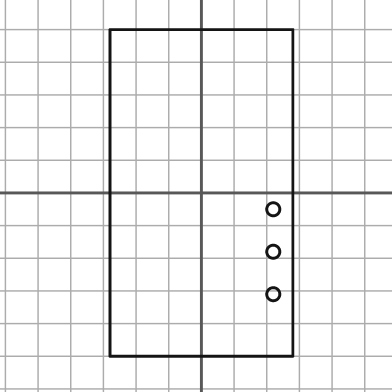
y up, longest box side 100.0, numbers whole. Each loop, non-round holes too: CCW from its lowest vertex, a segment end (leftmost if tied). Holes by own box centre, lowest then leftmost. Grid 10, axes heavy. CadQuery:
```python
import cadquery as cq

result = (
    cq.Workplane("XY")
    .moveTo(-28.0, -50.0)
    .lineTo(28.0, -50.0)
    .lineTo(28.0, 50.0)
    .lineTo(-28.0, 50.0)
    .close()
    .moveTo(22.0, -31.0)
    .circle(2.0)
    .moveTo(22.0, -18.0)
    .circle(2.0)
    .moveTo(22.0, -5.0)
    .circle(2.0)
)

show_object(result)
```